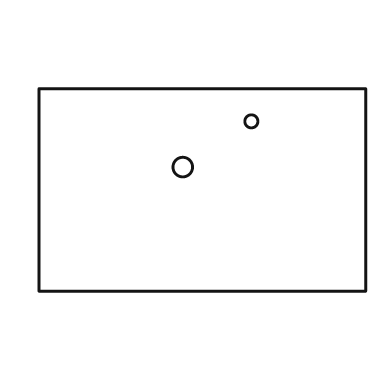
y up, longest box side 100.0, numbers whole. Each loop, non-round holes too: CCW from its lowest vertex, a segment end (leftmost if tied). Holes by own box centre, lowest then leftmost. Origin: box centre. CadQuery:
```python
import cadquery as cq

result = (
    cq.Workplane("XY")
    .moveTo(-50.0, -31.0)
    .lineTo(50.0, -31.0)
    .lineTo(50.0, 31.0)
    .lineTo(-50.0, 31.0)
    .close()
    .moveTo(-6.0, 7.0)
    .circle(3.0)
    .moveTo(15.0, 21.0)
    .circle(2.0)
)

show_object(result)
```